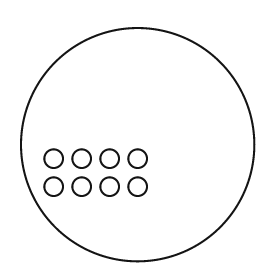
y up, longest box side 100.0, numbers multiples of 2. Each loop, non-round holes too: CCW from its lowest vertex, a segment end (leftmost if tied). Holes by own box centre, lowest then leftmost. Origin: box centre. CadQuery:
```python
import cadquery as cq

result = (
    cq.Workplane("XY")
    .moveTo(0.0, 0.0)
    .circle(50.0)
    .moveTo(-36.0, -18.0)
    .circle(4.0)
    .moveTo(-24.0, -18.0)
    .circle(4.0)
    .moveTo(-12.0, -18.0)
    .circle(4.0)
    .moveTo(0.0, -18.0)
    .circle(4.0)
    .moveTo(-36.0, -6.0)
    .circle(4.0)
    .moveTo(-24.0, -6.0)
    .circle(4.0)
    .moveTo(-12.0, -6.0)
    .circle(4.0)
    .moveTo(0.0, -6.0)
    .circle(4.0)
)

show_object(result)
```